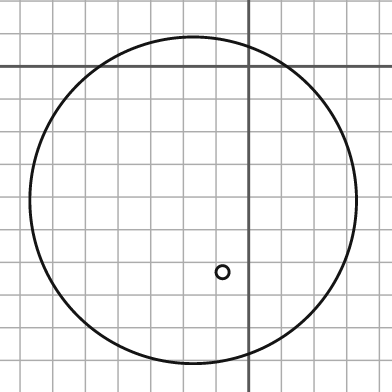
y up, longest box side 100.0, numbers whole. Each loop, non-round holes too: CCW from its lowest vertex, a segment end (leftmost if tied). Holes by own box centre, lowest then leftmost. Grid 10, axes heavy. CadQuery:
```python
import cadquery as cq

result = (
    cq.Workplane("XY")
    .moveTo(-17.0, -41.0)
    .circle(50.0)
    .moveTo(-8.0, -63.0)
    .circle(2.0)
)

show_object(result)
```